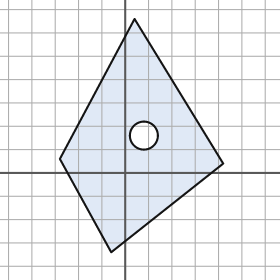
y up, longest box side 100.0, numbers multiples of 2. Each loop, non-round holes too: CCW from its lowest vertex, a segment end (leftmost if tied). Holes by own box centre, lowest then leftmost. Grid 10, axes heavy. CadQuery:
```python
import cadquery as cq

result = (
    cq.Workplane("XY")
    .moveTo(-6.0, -34.0)
    .lineTo(42.0, 4.0)
    .lineTo(4.0, 66.0)
    .lineTo(-28.0, 6.0)
    .close()
    .moveTo(8.0, 16.0)
    .circle(6.0)
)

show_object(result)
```